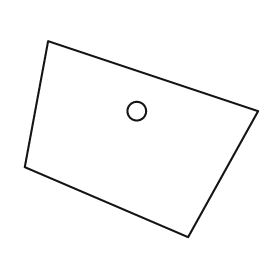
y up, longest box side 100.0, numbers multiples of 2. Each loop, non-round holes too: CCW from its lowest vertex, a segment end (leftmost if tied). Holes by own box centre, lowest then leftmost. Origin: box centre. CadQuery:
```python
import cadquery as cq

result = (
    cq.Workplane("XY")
    .moveTo(20.0, -42.0)
    .lineTo(50.0, 12.0)
    .lineTo(-40.0, 42.0)
    .lineTo(-50.0, -12.0)
    .close()
    .moveTo(-2.0, 12.0)
    .circle(4.0)
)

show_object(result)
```